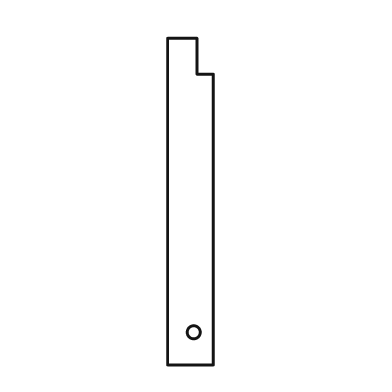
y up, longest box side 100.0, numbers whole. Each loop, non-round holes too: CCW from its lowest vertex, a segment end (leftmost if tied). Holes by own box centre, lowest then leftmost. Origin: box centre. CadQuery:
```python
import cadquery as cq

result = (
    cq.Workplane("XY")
    .moveTo(-7.0, -50.0)
    .lineTo(7.0, -50.0)
    .lineTo(7.0, 39.0)
    .lineTo(2.0, 39.0)
    .lineTo(2.0, 50.0)
    .lineTo(-7.0, 50.0)
    .close()
    .moveTo(1.0, -40.0)
    .circle(2.0)
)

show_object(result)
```